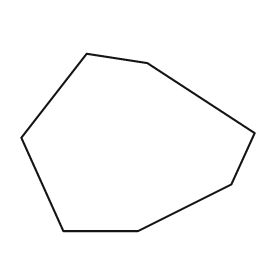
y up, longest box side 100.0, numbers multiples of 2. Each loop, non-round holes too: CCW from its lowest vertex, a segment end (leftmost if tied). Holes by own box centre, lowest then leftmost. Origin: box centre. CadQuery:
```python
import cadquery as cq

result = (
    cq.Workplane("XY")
    .moveTo(-32.0, -38.0)
    .lineTo(0.0, -38.0)
    .lineTo(40.0, -18.0)
    .lineTo(50.0, 4.0)
    .lineTo(4.0, 34.0)
    .lineTo(-22.0, 38.0)
    .lineTo(-50.0, 2.0)
    .close()
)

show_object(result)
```